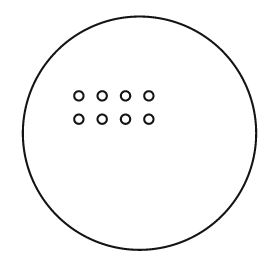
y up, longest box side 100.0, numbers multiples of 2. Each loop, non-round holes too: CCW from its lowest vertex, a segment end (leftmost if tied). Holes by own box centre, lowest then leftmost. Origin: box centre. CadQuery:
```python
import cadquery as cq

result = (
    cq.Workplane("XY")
    .moveTo(0.0, 0.0)
    .circle(50.0)
    .moveTo(-26.0, 6.0)
    .circle(2.0)
    .moveTo(-16.0, 6.0)
    .circle(2.0)
    .moveTo(-6.0, 6.0)
    .circle(2.0)
    .moveTo(4.0, 6.0)
    .circle(2.0)
    .moveTo(-26.0, 16.0)
    .circle(2.0)
    .moveTo(-16.0, 16.0)
    .circle(2.0)
    .moveTo(-6.0, 16.0)
    .circle(2.0)
    .moveTo(4.0, 16.0)
    .circle(2.0)
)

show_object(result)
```